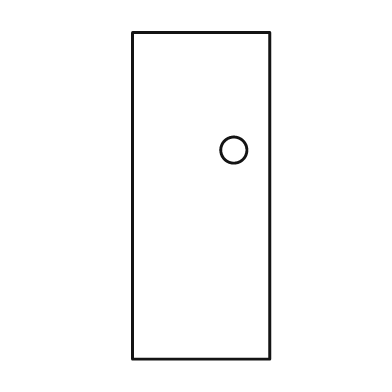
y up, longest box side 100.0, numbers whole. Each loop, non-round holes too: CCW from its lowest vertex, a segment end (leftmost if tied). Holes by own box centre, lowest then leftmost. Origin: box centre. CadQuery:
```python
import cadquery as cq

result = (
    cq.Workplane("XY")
    .moveTo(-21.0, -50.0)
    .lineTo(21.0, -50.0)
    .lineTo(21.0, 50.0)
    .lineTo(-21.0, 50.0)
    .close()
    .moveTo(10.0, 14.0)
    .circle(4.0)
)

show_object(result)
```